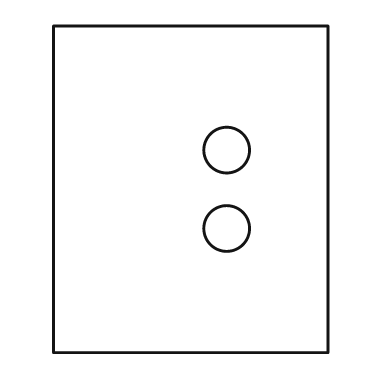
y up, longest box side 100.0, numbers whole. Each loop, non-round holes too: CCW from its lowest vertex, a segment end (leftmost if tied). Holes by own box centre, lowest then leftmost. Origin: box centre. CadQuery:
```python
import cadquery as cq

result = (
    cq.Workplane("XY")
    .moveTo(-42.0, -50.0)
    .lineTo(42.0, -50.0)
    .lineTo(42.0, 50.0)
    .lineTo(-42.0, 50.0)
    .close()
    .moveTo(11.0, -12.0)
    .circle(7.0)
    .moveTo(11.0, 12.0)
    .circle(7.0)
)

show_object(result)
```